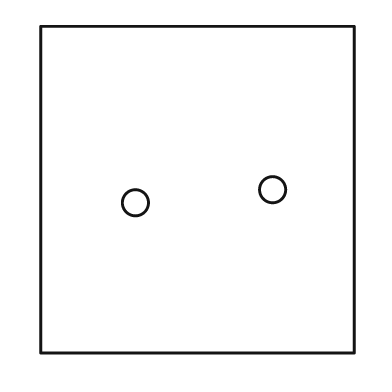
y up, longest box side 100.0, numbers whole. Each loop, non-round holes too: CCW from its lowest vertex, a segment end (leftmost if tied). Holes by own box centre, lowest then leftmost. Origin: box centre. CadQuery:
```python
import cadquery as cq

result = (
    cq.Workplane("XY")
    .moveTo(-48.0, -50.0)
    .lineTo(48.0, -50.0)
    .lineTo(48.0, 50.0)
    .lineTo(-48.0, 50.0)
    .close()
    .moveTo(-19.0, -4.0)
    .circle(4.0)
    .moveTo(23.0, 0.0)
    .circle(4.0)
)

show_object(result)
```